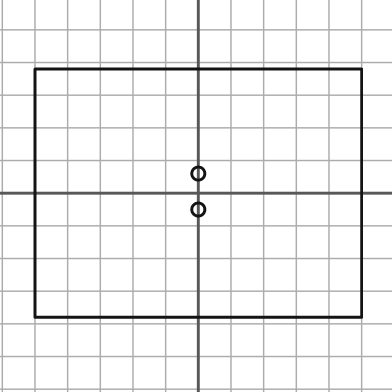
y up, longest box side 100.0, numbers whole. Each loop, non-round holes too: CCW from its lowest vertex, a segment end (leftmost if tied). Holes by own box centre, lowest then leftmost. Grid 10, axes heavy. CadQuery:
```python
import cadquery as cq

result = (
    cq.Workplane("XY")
    .moveTo(-50.0, -38.0)
    .lineTo(50.0, -38.0)
    .lineTo(50.0, 38.0)
    .lineTo(-50.0, 38.0)
    .close()
    .moveTo(0.0, -5.0)
    .circle(2.0)
    .moveTo(0.0, 6.0)
    .circle(2.0)
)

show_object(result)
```